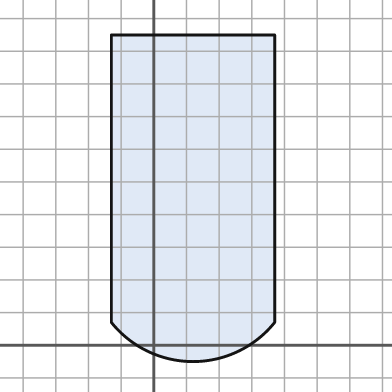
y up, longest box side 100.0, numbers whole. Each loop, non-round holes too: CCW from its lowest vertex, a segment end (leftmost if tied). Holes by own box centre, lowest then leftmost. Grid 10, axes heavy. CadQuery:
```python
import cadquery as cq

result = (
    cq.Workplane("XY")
    .moveTo(-13.0, 7.0)
    .threePointArc((12.0, -5.0), (37.0, 7.0))
    .lineTo(37.0, 95.0)
    .lineTo(-13.0, 95.0)
    .close()
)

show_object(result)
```